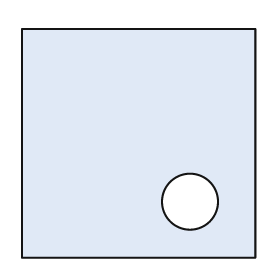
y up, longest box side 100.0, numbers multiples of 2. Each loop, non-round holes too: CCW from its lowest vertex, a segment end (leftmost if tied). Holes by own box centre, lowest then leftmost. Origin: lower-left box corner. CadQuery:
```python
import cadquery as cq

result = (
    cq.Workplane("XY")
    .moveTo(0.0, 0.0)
    .lineTo(100.0, 0.0)
    .lineTo(100.0, 98.0)
    .lineTo(0.0, 98.0)
    .close()
    .moveTo(72.0, 24.0)
    .circle(12.0)
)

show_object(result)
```